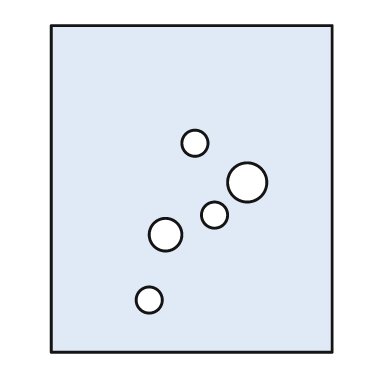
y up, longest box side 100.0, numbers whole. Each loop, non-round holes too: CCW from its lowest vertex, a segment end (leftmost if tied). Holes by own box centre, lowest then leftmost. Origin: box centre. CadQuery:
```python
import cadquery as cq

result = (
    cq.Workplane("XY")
    .moveTo(-43.0, -50.0)
    .lineTo(43.0, -50.0)
    .lineTo(43.0, 50.0)
    .lineTo(-43.0, 50.0)
    .close()
    .moveTo(-13.0, -34.0)
    .circle(4.0)
    .moveTo(-8.0, -14.0)
    .circle(5.0)
    .moveTo(7.0, -8.0)
    .circle(4.0)
    .moveTo(17.0, 2.0)
    .circle(6.0)
    .moveTo(1.0, 14.0)
    .circle(4.0)
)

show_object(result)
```